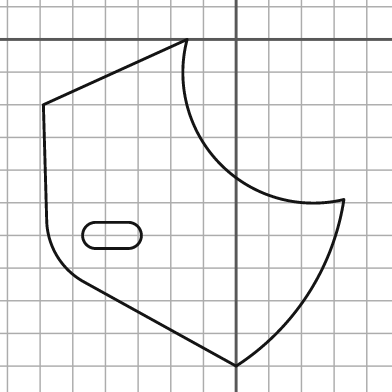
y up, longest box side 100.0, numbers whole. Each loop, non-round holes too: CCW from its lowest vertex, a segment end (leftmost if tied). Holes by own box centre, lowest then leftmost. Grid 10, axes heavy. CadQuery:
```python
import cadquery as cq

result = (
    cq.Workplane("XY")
    .moveTo(0.0, -100.0)
    .threePointArc((22.0, -78.0), (33.0, -49.0))
    .threePointArc((-5.0, -38.0), (-15.0, 0.0))
    .lineTo(-59.0, -20.0)
    .lineTo(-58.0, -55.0)
    .threePointArc((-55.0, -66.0), (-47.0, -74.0))
    .close()
    .moveTo(-43.0, -64.0)
    .lineTo(-33.0, -64.0)
    .threePointArc((-29.0, -60.0), (-33.0, -56.0))
    .lineTo(-43.0, -56.0)
    .threePointArc((-47.0, -60.0), (-43.0, -64.0))
    .close()
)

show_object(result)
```